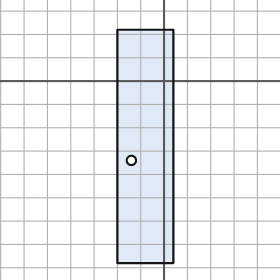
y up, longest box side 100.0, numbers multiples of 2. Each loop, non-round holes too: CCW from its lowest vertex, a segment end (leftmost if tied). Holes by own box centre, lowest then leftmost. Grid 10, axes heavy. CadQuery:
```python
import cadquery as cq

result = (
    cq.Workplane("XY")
    .moveTo(-20.0, -78.0)
    .lineTo(4.0, -78.0)
    .lineTo(4.0, 22.0)
    .lineTo(-20.0, 22.0)
    .close()
    .moveTo(-14.0, -34.0)
    .circle(2.0)
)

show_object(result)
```